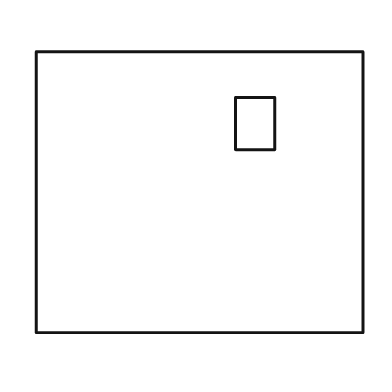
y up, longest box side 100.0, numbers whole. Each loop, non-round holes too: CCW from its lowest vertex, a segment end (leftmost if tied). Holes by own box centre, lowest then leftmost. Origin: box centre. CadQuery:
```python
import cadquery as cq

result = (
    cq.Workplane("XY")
    .moveTo(-50.0, -43.0)
    .lineTo(50.0, -43.0)
    .lineTo(50.0, 43.0)
    .lineTo(-50.0, 43.0)
    .close()
    .moveTo(11.0, 13.0)
    .lineTo(23.0, 13.0)
    .lineTo(23.0, 29.0)
    .lineTo(11.0, 29.0)
    .close()
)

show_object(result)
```